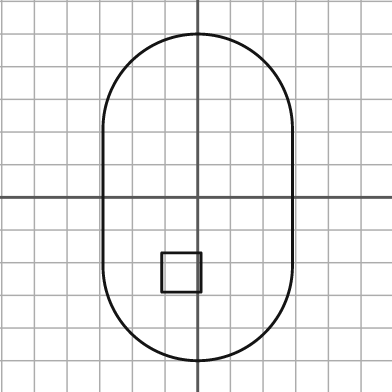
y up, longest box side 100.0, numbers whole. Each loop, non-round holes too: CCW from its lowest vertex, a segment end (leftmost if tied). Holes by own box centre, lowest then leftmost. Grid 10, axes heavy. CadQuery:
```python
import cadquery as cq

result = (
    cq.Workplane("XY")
    .moveTo(-29.0, -21.0)
    .threePointArc((0.0, -50.0), (29.0, -21.0))
    .lineTo(29.0, 21.0)
    .threePointArc((0.0, 50.0), (-29.0, 21.0))
    .close()
    .moveTo(-11.0, -29.0)
    .lineTo(1.0, -29.0)
    .lineTo(1.0, -17.0)
    .lineTo(-11.0, -17.0)
    .close()
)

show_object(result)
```